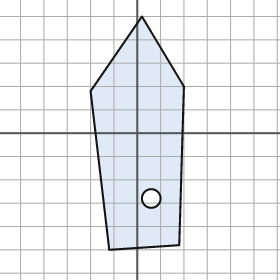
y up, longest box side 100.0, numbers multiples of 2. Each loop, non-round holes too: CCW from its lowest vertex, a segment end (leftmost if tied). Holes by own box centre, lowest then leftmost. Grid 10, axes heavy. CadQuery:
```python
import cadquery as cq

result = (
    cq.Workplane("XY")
    .moveTo(-12.0, -50.0)
    .lineTo(18.0, -48.0)
    .lineTo(20.0, 20.0)
    .lineTo(2.0, 50.0)
    .lineTo(-20.0, 18.0)
    .close()
    .moveTo(6.0, -28.0)
    .circle(4.0)
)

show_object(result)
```